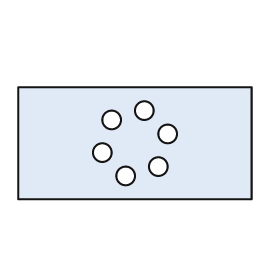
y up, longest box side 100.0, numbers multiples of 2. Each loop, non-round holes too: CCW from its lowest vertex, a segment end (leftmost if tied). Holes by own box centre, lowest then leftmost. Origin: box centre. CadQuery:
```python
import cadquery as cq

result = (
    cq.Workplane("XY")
    .moveTo(-50.0, -24.0)
    .lineTo(50.0, -24.0)
    .lineTo(50.0, 24.0)
    .lineTo(-50.0, 24.0)
    .close()
    .moveTo(-4.0, -14.0)
    .circle(4.0)
    .moveTo(10.0, -10.0)
    .circle(4.0)
    .moveTo(-14.0, -4.0)
    .circle(4.0)
    .moveTo(14.0, 4.0)
    .circle(4.0)
    .moveTo(-10.0, 10.0)
    .circle(4.0)
    .moveTo(4.0, 14.0)
    .circle(4.0)
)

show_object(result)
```